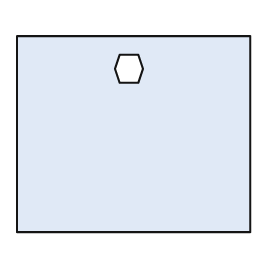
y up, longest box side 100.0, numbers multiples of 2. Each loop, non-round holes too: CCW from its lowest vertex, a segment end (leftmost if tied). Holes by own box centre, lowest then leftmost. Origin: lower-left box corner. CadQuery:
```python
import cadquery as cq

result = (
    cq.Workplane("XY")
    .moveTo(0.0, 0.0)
    .lineTo(100.0, 0.0)
    .lineTo(100.0, 84.0)
    .lineTo(0.0, 84.0)
    .close()
    .moveTo(44.0, 64.0)
    .lineTo(52.0, 64.0)
    .lineTo(54.0, 70.0)
    .lineTo(52.0, 76.0)
    .lineTo(44.0, 76.0)
    .lineTo(42.0, 70.0)
    .close()
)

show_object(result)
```